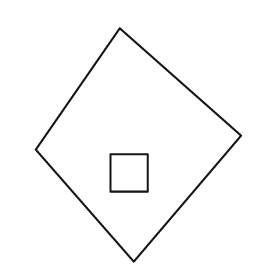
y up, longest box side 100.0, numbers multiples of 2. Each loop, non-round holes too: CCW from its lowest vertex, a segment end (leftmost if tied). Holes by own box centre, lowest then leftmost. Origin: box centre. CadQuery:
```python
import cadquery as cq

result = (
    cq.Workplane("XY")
    .moveTo(-2.0, -50.0)
    .lineTo(44.0, 4.0)
    .lineTo(-8.0, 50.0)
    .lineTo(-44.0, -2.0)
    .close()
    .moveTo(-12.0, -20.0)
    .lineTo(4.0, -20.0)
    .lineTo(4.0, -4.0)
    .lineTo(-12.0, -4.0)
    .close()
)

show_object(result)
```